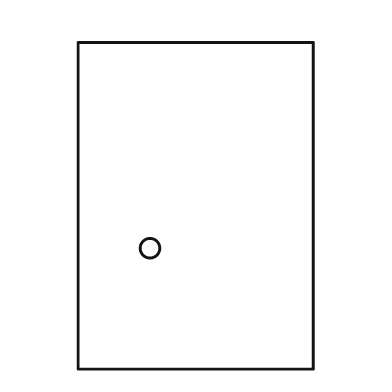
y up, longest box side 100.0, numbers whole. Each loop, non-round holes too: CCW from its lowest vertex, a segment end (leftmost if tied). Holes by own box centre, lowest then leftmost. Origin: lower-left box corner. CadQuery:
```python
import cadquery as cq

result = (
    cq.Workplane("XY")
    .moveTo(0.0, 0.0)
    .lineTo(72.0, 0.0)
    .lineTo(72.0, 100.0)
    .lineTo(0.0, 100.0)
    .close()
    .moveTo(22.0, 37.0)
    .circle(3.0)
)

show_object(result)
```